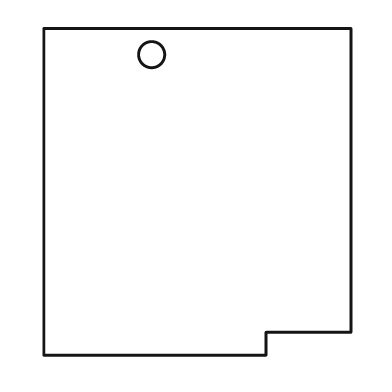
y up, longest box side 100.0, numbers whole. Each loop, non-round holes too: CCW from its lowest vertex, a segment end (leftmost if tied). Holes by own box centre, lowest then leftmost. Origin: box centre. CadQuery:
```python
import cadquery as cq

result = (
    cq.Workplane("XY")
    .moveTo(-47.0, -50.0)
    .lineTo(21.0, -50.0)
    .lineTo(21.0, -43.0)
    .lineTo(47.0, -43.0)
    .lineTo(47.0, 50.0)
    .lineTo(-47.0, 50.0)
    .close()
    .moveTo(-14.0, 42.0)
    .circle(4.0)
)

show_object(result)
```